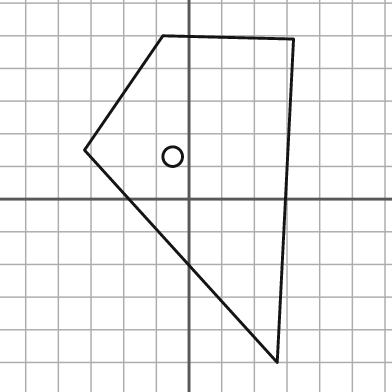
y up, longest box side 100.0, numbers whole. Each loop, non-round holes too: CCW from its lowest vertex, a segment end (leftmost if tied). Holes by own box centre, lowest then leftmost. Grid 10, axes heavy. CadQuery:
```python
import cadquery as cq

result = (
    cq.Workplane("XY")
    .moveTo(27.0, -50.0)
    .lineTo(32.0, 49.0)
    .lineTo(-8.0, 50.0)
    .lineTo(-32.0, 15.0)
    .close()
    .moveTo(-5.0, 13.0)
    .circle(3.0)
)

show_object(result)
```